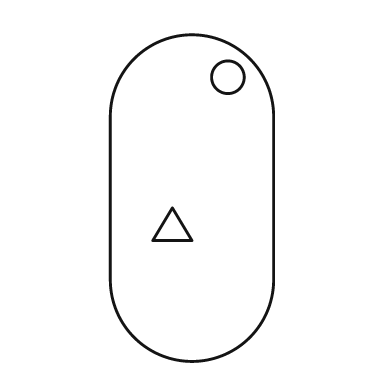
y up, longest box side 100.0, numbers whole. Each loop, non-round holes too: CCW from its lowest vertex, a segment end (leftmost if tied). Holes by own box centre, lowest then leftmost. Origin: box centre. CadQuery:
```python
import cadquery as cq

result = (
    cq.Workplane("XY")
    .moveTo(-25.0, -25.0)
    .threePointArc((0.0, -50.0), (25.0, -25.0))
    .lineTo(25.0, 25.0)
    .threePointArc((0.0, 50.0), (-25.0, 25.0))
    .close()
    .moveTo(-12.0, -13.0)
    .lineTo(0.0, -13.0)
    .lineTo(-6.0, -3.0)
    .close()
    .moveTo(11.0, 37.0)
    .circle(5.0)
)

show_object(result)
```